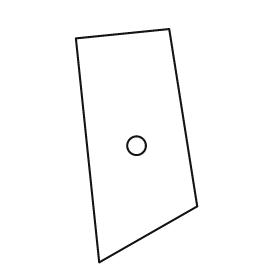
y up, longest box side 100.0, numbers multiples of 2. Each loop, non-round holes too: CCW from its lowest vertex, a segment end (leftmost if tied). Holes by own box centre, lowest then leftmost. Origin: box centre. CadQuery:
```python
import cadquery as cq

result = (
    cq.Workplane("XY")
    .moveTo(-16.0, -50.0)
    .lineTo(26.0, -26.0)
    .lineTo(14.0, 50.0)
    .lineTo(-26.0, 46.0)
    .close()
    .moveTo(0.0, 0.0)
    .circle(4.0)
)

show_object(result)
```